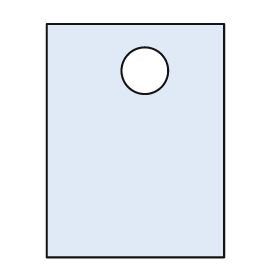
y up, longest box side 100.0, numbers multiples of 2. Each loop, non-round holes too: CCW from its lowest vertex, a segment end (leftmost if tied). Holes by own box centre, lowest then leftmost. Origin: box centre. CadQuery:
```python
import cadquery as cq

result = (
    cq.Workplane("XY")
    .moveTo(-38.0, -50.0)
    .lineTo(38.0, -50.0)
    .lineTo(38.0, 50.0)
    .lineTo(-38.0, 50.0)
    .close()
    .moveTo(4.0, 30.0)
    .circle(10.0)
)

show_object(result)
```